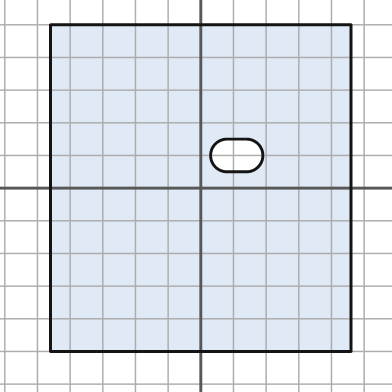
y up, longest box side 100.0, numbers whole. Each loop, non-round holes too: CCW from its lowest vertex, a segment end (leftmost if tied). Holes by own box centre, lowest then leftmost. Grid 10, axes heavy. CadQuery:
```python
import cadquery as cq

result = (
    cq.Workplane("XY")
    .moveTo(-46.0, -50.0)
    .lineTo(46.0, -50.0)
    .lineTo(46.0, 50.0)
    .lineTo(-46.0, 50.0)
    .close()
    .moveTo(8.0, 5.0)
    .lineTo(14.0, 5.0)
    .threePointArc((19.0, 10.0), (14.0, 15.0))
    .lineTo(8.0, 15.0)
    .threePointArc((3.0, 10.0), (8.0, 5.0))
    .close()
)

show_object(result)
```